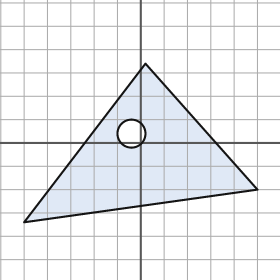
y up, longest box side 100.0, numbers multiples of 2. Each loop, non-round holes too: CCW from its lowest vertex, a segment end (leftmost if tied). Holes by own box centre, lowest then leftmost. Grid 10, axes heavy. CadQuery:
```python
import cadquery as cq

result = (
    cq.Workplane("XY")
    .moveTo(-50.0, -34.0)
    .lineTo(50.0, -20.0)
    .lineTo(2.0, 34.0)
    .close()
    .moveTo(-4.0, 4.0)
    .circle(6.0)
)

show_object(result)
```